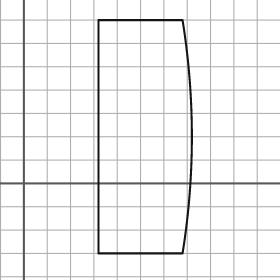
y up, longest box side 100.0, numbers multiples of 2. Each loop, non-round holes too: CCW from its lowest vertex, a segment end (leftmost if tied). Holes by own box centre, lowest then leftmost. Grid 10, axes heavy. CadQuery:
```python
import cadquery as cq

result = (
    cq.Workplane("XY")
    .moveTo(32.0, -30.0)
    .lineTo(68.0, -30.0)
    .threePointArc((72.0, 20.0), (68.0, 70.0))
    .lineTo(32.0, 70.0)
    .close()
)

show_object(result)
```